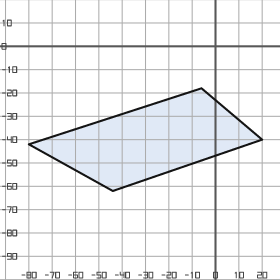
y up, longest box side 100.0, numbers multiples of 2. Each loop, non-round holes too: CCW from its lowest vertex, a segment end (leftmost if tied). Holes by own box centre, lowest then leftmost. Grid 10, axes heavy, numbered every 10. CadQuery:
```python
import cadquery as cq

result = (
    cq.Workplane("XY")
    .moveTo(-44.0, -62.0)
    .lineTo(20.0, -40.0)
    .lineTo(-6.0, -18.0)
    .lineTo(-80.0, -42.0)
    .close()
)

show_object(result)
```